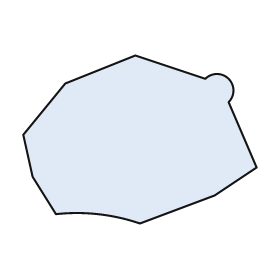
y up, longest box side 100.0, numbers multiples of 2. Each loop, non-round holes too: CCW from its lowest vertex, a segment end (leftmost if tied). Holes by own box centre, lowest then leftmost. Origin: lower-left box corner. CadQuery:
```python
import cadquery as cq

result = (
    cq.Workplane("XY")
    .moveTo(50.0, 0.0)
    .lineTo(82.0, 12.0)
    .lineTo(100.0, 24.0)
    .lineTo(88.0, 52.0)
    .threePointArc((88.0, 62.0), (78.0, 62.0))
    .lineTo(48.0, 72.0)
    .lineTo(18.0, 60.0)
    .lineTo(0.0, 38.0)
    .lineTo(4.0, 20.0)
    .lineTo(14.0, 4.0)
    .threePointArc((32.0, 4.0), (50.0, 0.0))
    .close()
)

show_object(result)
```